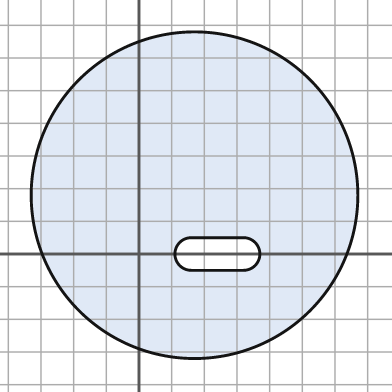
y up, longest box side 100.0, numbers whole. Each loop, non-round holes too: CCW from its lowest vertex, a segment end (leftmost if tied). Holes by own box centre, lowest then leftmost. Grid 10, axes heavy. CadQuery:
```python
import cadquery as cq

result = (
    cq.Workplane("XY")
    .moveTo(17.0, 18.0)
    .circle(50.0)
    .moveTo(16.0, -5.0)
    .lineTo(32.0, -5.0)
    .threePointArc((37.0, 0.0), (32.0, 5.0))
    .lineTo(16.0, 5.0)
    .threePointArc((11.0, 0.0), (16.0, -5.0))
    .close()
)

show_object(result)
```